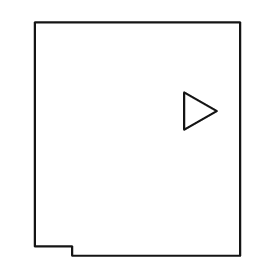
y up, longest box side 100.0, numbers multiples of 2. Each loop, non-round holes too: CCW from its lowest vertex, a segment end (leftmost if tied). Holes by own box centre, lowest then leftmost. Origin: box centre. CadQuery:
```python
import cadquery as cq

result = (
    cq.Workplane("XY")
    .moveTo(-28.0, -50.0)
    .lineTo(44.0, -50.0)
    .lineTo(44.0, 50.0)
    .lineTo(-44.0, 50.0)
    .lineTo(-44.0, -46.0)
    .lineTo(-28.0, -46.0)
    .close()
    .moveTo(20.0, 4.0)
    .lineTo(34.0, 12.0)
    .lineTo(20.0, 20.0)
    .close()
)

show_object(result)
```